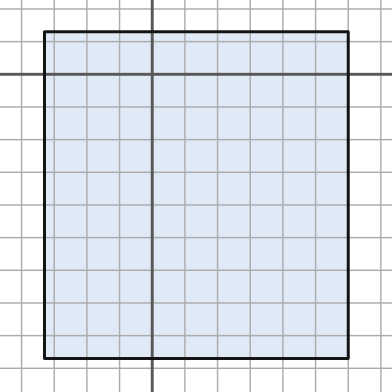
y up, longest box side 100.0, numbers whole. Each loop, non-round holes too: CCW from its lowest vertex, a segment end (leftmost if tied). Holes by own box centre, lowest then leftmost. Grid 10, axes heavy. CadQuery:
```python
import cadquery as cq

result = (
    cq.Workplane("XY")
    .moveTo(-33.0, -87.0)
    .lineTo(60.0, -87.0)
    .lineTo(60.0, 13.0)
    .lineTo(-33.0, 13.0)
    .close()
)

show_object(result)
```